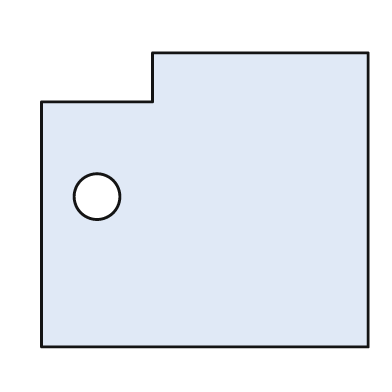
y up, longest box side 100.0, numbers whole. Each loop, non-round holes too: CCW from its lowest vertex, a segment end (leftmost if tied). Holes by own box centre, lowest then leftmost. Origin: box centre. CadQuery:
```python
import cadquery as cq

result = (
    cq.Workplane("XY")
    .moveTo(-50.0, -45.0)
    .lineTo(50.0, -45.0)
    .lineTo(50.0, 45.0)
    .lineTo(-16.0, 45.0)
    .lineTo(-16.0, 30.0)
    .lineTo(-50.0, 30.0)
    .close()
    .moveTo(-33.0, 1.0)
    .circle(7.0)
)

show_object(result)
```